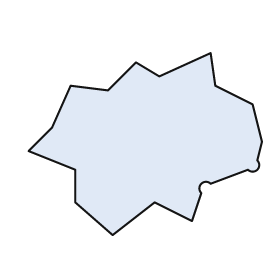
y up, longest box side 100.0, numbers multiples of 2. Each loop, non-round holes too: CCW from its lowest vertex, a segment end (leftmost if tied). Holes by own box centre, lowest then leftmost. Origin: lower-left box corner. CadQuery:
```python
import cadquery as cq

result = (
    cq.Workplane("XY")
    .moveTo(36.0, 0.0)
    .lineTo(54.0, 14.0)
    .lineTo(70.0, 6.0)
    .lineTo(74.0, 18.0)
    .threePointArc((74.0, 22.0), (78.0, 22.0))
    .lineTo(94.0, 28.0)
    .threePointArc((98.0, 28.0), (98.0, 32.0))
    .lineTo(100.0, 40.0)
    .lineTo(96.0, 56.0)
    .lineTo(80.0, 64.0)
    .lineTo(78.0, 78.0)
    .lineTo(56.0, 68.0)
    .lineTo(46.0, 74.0)
    .lineTo(34.0, 62.0)
    .lineTo(18.0, 64.0)
    .lineTo(10.0, 46.0)
    .lineTo(0.0, 36.0)
    .lineTo(20.0, 28.0)
    .lineTo(20.0, 14.0)
    .close()
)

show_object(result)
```